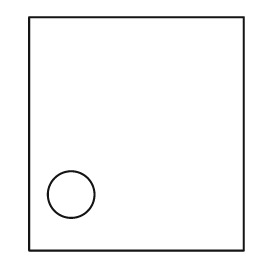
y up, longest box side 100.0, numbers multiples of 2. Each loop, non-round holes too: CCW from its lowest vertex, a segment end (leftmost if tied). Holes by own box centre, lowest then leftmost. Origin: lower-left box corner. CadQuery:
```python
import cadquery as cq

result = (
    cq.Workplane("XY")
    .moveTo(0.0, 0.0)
    .lineTo(92.0, 0.0)
    .lineTo(92.0, 100.0)
    .lineTo(0.0, 100.0)
    .close()
    .moveTo(18.0, 24.0)
    .circle(10.0)
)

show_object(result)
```